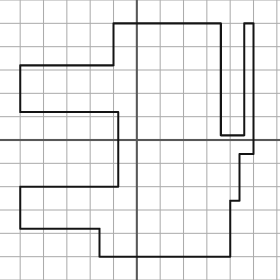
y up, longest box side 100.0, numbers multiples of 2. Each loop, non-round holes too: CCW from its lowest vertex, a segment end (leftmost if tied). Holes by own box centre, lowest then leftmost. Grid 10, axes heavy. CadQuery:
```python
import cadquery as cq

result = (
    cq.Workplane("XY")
    .moveTo(-16.0, -50.0)
    .lineTo(40.0, -50.0)
    .lineTo(40.0, -26.0)
    .lineTo(44.0, -26.0)
    .lineTo(44.0, -6.0)
    .lineTo(50.0, -6.0)
    .lineTo(50.0, 50.0)
    .lineTo(46.0, 50.0)
    .lineTo(46.0, 2.0)
    .lineTo(36.0, 2.0)
    .lineTo(36.0, 50.0)
    .lineTo(-10.0, 50.0)
    .lineTo(-10.0, 32.0)
    .lineTo(-50.0, 32.0)
    .lineTo(-50.0, 12.0)
    .lineTo(-8.0, 12.0)
    .lineTo(-8.0, -20.0)
    .lineTo(-50.0, -20.0)
    .lineTo(-50.0, -38.0)
    .lineTo(-16.0, -38.0)
    .close()
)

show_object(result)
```